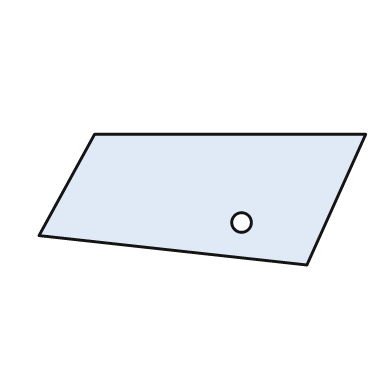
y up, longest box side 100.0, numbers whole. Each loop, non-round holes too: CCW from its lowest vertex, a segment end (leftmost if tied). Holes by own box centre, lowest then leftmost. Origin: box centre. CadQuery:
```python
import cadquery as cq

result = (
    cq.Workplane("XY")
    .moveTo(32.0, -20.0)
    .lineTo(50.0, 20.0)
    .lineTo(-33.0, 20.0)
    .lineTo(-50.0, -11.0)
    .close()
    .moveTo(12.0, -7.0)
    .circle(3.0)
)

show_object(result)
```